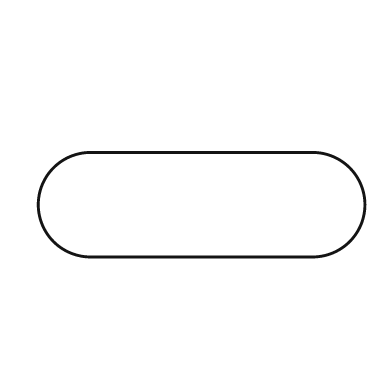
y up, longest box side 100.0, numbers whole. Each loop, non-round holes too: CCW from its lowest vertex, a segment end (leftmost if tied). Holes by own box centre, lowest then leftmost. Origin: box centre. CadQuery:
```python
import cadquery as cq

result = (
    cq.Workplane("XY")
    .moveTo(-34.0, -16.0)
    .lineTo(34.0, -16.0)
    .threePointArc((50.0, 0.0), (34.0, 16.0))
    .lineTo(-34.0, 16.0)
    .threePointArc((-50.0, 0.0), (-34.0, -16.0))
    .close()
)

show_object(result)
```